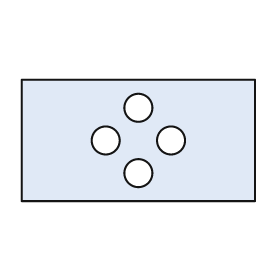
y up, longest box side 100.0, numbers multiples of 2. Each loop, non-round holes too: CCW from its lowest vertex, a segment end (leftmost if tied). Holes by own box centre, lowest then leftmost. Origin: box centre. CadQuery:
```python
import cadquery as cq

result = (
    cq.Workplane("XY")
    .moveTo(-50.0, -26.0)
    .lineTo(50.0, -26.0)
    .lineTo(50.0, 26.0)
    .lineTo(-50.0, 26.0)
    .close()
    .moveTo(0.0, -14.0)
    .circle(6.0)
    .moveTo(-14.0, 0.0)
    .circle(6.0)
    .moveTo(14.0, 0.0)
    .circle(6.0)
    .moveTo(0.0, 14.0)
    .circle(6.0)
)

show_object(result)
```